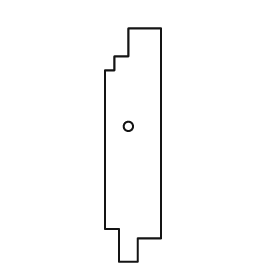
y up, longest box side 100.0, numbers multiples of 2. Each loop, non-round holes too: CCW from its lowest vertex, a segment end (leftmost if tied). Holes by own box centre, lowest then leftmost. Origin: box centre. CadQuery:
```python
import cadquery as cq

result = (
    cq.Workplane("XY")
    .moveTo(-6.0, -50.0)
    .lineTo(2.0, -50.0)
    .lineTo(2.0, -40.0)
    .lineTo(12.0, -40.0)
    .lineTo(12.0, 50.0)
    .lineTo(-2.0, 50.0)
    .lineTo(-2.0, 38.0)
    .lineTo(-8.0, 38.0)
    .lineTo(-8.0, 32.0)
    .lineTo(-12.0, 32.0)
    .lineTo(-12.0, -36.0)
    .lineTo(-6.0, -36.0)
    .close()
    .moveTo(-2.0, 8.0)
    .circle(2.0)
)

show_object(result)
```